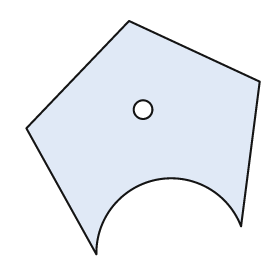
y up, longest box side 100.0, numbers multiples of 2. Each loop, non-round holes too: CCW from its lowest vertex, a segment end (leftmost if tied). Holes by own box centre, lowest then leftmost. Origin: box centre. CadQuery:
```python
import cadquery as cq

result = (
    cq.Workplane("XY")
    .moveTo(-20.0, -50.0)
    .threePointArc((6.0, -18.0), (42.0, -38.0))
    .lineTo(50.0, 24.0)
    .lineTo(-6.0, 50.0)
    .lineTo(-50.0, 4.0)
    .close()
    .moveTo(0.0, 12.0)
    .circle(4.0)
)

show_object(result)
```